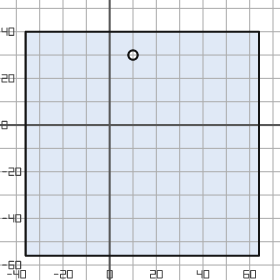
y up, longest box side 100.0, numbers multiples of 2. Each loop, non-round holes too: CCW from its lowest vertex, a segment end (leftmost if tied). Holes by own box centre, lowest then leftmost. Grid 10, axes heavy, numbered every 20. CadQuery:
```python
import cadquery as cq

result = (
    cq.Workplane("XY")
    .moveTo(-36.0, -56.0)
    .lineTo(64.0, -56.0)
    .lineTo(64.0, 40.0)
    .lineTo(-36.0, 40.0)
    .close()
    .moveTo(10.0, 30.0)
    .circle(2.0)
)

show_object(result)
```